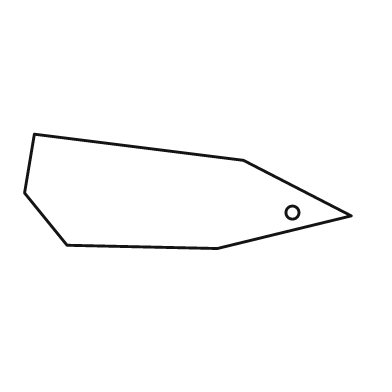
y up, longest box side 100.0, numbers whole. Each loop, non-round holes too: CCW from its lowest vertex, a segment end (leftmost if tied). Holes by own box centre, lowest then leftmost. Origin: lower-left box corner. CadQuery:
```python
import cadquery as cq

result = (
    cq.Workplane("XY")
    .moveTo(59.0, 0.0)
    .lineTo(100.0, 10.0)
    .lineTo(67.0, 27.0)
    .lineTo(3.0, 35.0)
    .lineTo(0.0, 17.0)
    .lineTo(13.0, 1.0)
    .close()
    .moveTo(82.0, 11.0)
    .circle(2.0)
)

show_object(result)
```